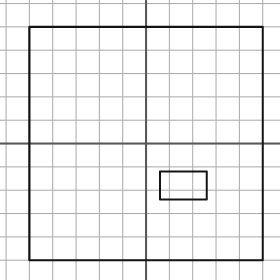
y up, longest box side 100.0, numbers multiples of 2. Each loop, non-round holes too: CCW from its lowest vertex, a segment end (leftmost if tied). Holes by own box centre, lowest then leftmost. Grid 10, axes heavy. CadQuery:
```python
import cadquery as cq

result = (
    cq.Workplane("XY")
    .moveTo(-50.0, -50.0)
    .lineTo(50.0, -50.0)
    .lineTo(50.0, 50.0)
    .lineTo(-50.0, 50.0)
    .close()
    .moveTo(6.0, -24.0)
    .lineTo(26.0, -24.0)
    .lineTo(26.0, -12.0)
    .lineTo(6.0, -12.0)
    .close()
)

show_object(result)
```